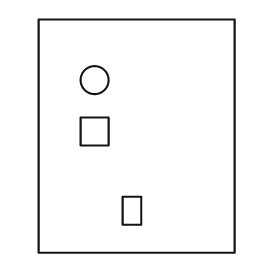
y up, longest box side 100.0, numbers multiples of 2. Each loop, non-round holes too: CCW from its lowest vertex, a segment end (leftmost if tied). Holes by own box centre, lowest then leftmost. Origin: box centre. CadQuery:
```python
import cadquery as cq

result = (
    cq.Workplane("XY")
    .moveTo(-42.0, -50.0)
    .lineTo(42.0, -50.0)
    .lineTo(42.0, 50.0)
    .lineTo(-42.0, 50.0)
    .close()
    .moveTo(-6.0, -38.0)
    .lineTo(2.0, -38.0)
    .lineTo(2.0, -26.0)
    .lineTo(-6.0, -26.0)
    .close()
    .moveTo(-24.0, -4.0)
    .lineTo(-12.0, -4.0)
    .lineTo(-12.0, 8.0)
    .lineTo(-24.0, 8.0)
    .close()
    .moveTo(-18.0, 24.0)
    .circle(6.0)
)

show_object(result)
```